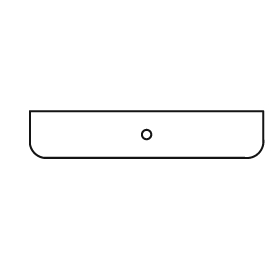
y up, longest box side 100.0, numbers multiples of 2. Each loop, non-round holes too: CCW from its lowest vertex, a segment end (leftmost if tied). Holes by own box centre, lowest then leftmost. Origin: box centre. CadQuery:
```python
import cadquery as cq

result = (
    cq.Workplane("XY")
    .moveTo(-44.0, -10.0)
    .lineTo(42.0, -10.0)
    .threePointArc((48.0, -8.0), (50.0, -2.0))
    .lineTo(50.0, 10.0)
    .lineTo(-50.0, 10.0)
    .lineTo(-50.0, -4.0)
    .threePointArc((-48.0, -8.0), (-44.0, -10.0))
    .close()
    .moveTo(0.0, 0.0)
    .circle(2.0)
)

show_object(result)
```